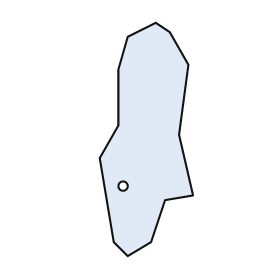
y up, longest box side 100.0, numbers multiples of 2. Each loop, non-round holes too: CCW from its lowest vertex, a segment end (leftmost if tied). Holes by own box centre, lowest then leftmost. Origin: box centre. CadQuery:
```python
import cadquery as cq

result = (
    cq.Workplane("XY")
    .moveTo(-8.0, -50.0)
    .lineTo(2.0, -44.0)
    .lineTo(8.0, -26.0)
    .lineTo(20.0, -24.0)
    .lineTo(14.0, 2.0)
    .lineTo(18.0, 32.0)
    .lineTo(10.0, 46.0)
    .lineTo(4.0, 50.0)
    .lineTo(-8.0, 44.0)
    .lineTo(-12.0, 30.0)
    .lineTo(-12.0, 6.0)
    .lineTo(-20.0, -8.0)
    .lineTo(-14.0, -44.0)
    .close()
    .moveTo(-10.0, -20.0)
    .circle(2.0)
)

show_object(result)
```